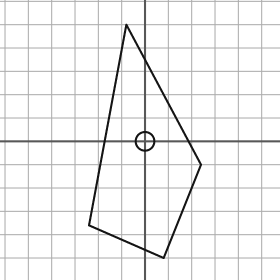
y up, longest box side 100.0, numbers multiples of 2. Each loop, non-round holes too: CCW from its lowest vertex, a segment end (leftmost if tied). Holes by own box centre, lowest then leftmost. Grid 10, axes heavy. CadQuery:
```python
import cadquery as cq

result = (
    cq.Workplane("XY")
    .moveTo(8.0, -50.0)
    .lineTo(24.0, -10.0)
    .lineTo(-8.0, 50.0)
    .lineTo(-24.0, -36.0)
    .close()
    .moveTo(0.0, 0.0)
    .circle(4.0)
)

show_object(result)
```